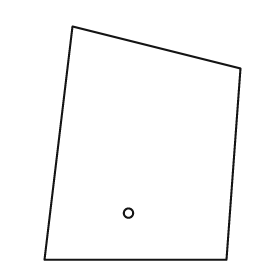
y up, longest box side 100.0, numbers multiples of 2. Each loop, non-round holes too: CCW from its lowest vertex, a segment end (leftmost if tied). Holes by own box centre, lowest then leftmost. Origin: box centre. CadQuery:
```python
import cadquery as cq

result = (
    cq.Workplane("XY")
    .moveTo(-42.0, -50.0)
    .lineTo(36.0, -50.0)
    .lineTo(42.0, 32.0)
    .lineTo(-30.0, 50.0)
    .close()
    .moveTo(-6.0, -30.0)
    .circle(2.0)
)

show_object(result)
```